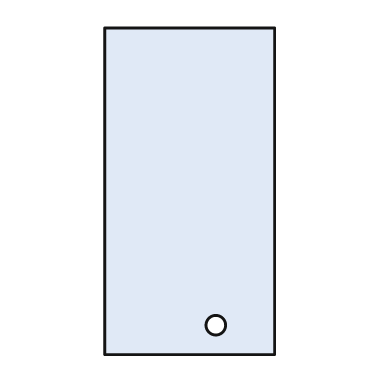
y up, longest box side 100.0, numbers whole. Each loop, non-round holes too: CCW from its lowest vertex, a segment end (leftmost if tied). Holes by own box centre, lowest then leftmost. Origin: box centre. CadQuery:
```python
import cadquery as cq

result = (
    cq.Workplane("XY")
    .moveTo(-26.0, -50.0)
    .lineTo(26.0, -50.0)
    .lineTo(26.0, 50.0)
    .lineTo(-26.0, 50.0)
    .close()
    .moveTo(8.0, -41.0)
    .circle(3.0)
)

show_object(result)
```